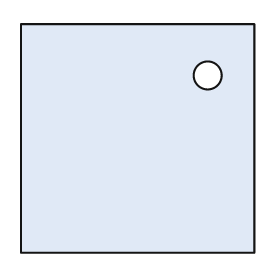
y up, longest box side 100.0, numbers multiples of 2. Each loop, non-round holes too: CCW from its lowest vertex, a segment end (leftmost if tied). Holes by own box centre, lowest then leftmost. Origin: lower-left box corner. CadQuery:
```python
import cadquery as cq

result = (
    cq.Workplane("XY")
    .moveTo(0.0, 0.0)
    .lineTo(100.0, 0.0)
    .lineTo(100.0, 98.0)
    .lineTo(0.0, 98.0)
    .close()
    .moveTo(80.0, 76.0)
    .circle(6.0)
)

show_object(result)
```